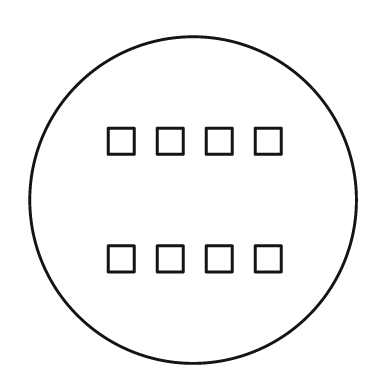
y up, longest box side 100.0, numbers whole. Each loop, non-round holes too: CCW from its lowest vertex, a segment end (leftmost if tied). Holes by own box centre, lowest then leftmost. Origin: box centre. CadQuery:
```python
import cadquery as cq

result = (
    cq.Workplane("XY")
    .moveTo(0.0, 0.0)
    .circle(50.0)
    .moveTo(-26.0, -22.0)
    .lineTo(-18.0, -22.0)
    .lineTo(-18.0, -14.0)
    .lineTo(-26.0, -14.0)
    .close()
    .moveTo(-11.0, -22.0)
    .lineTo(-3.0, -22.0)
    .lineTo(-3.0, -14.0)
    .lineTo(-11.0, -14.0)
    .close()
    .moveTo(4.0, -22.0)
    .lineTo(12.0, -22.0)
    .lineTo(12.0, -14.0)
    .lineTo(4.0, -14.0)
    .close()
    .moveTo(19.0, -22.0)
    .lineTo(27.0, -22.0)
    .lineTo(27.0, -14.0)
    .lineTo(19.0, -14.0)
    .close()
    .moveTo(-26.0, 14.0)
    .lineTo(-18.0, 14.0)
    .lineTo(-18.0, 22.0)
    .lineTo(-26.0, 22.0)
    .close()
    .moveTo(-11.0, 14.0)
    .lineTo(-3.0, 14.0)
    .lineTo(-3.0, 22.0)
    .lineTo(-11.0, 22.0)
    .close()
    .moveTo(4.0, 14.0)
    .lineTo(12.0, 14.0)
    .lineTo(12.0, 22.0)
    .lineTo(4.0, 22.0)
    .close()
    .moveTo(19.0, 14.0)
    .lineTo(27.0, 14.0)
    .lineTo(27.0, 22.0)
    .lineTo(19.0, 22.0)
    .close()
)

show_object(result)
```